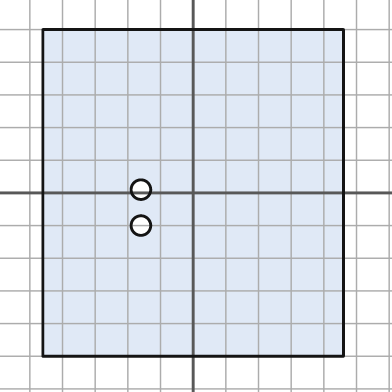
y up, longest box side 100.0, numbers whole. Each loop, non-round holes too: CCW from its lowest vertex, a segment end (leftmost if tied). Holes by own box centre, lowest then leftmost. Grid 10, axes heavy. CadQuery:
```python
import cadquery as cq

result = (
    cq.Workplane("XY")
    .moveTo(-46.0, -50.0)
    .lineTo(46.0, -50.0)
    .lineTo(46.0, 50.0)
    .lineTo(-46.0, 50.0)
    .close()
    .moveTo(-16.0, -10.0)
    .circle(3.0)
    .moveTo(-16.0, 1.0)
    .circle(3.0)
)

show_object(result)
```